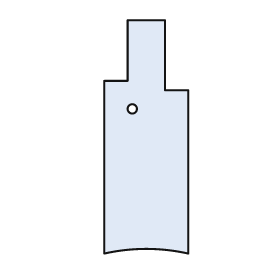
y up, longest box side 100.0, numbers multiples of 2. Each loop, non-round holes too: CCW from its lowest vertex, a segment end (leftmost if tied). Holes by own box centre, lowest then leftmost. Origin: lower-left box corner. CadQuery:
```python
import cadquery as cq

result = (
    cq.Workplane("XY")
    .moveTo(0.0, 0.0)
    .threePointArc((18.0, 2.0), (36.0, 0.0))
    .lineTo(36.0, 70.0)
    .lineTo(26.0, 70.0)
    .lineTo(26.0, 100.0)
    .lineTo(10.0, 100.0)
    .lineTo(10.0, 74.0)
    .lineTo(0.0, 74.0)
    .close()
    .moveTo(12.0, 62.0)
    .circle(2.0)
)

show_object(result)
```